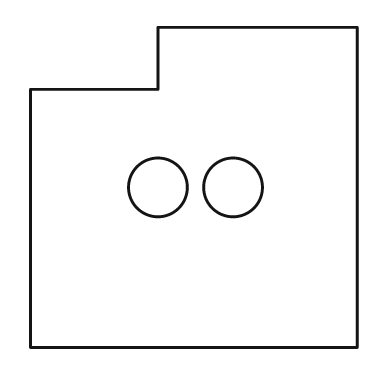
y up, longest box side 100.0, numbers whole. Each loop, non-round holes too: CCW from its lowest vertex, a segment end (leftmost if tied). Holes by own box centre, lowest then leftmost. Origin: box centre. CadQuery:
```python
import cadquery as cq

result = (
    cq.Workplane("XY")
    .moveTo(-50.0, -49.0)
    .lineTo(50.0, -49.0)
    .lineTo(50.0, 49.0)
    .lineTo(-11.0, 49.0)
    .lineTo(-11.0, 30.0)
    .lineTo(-50.0, 30.0)
    .close()
    .moveTo(-11.0, 0.0)
    .circle(9.0)
    .moveTo(12.0, 0.0)
    .circle(9.0)
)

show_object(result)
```